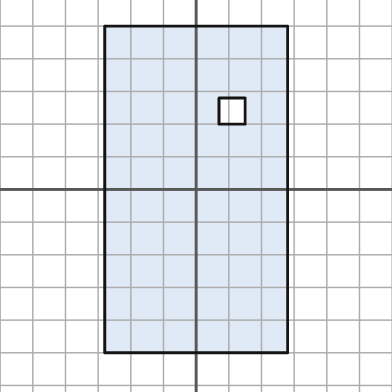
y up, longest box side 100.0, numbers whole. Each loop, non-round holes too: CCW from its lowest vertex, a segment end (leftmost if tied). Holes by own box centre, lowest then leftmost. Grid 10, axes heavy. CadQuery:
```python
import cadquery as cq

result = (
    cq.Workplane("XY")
    .moveTo(-28.0, -50.0)
    .lineTo(28.0, -50.0)
    .lineTo(28.0, 50.0)
    .lineTo(-28.0, 50.0)
    .close()
    .moveTo(7.0, 20.0)
    .lineTo(15.0, 20.0)
    .lineTo(15.0, 28.0)
    .lineTo(7.0, 28.0)
    .close()
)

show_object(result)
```